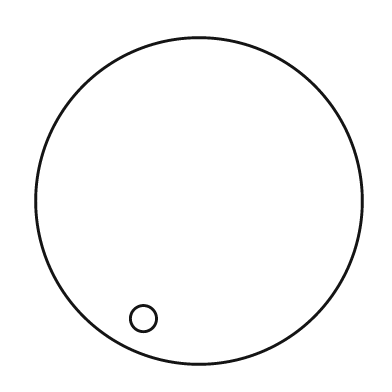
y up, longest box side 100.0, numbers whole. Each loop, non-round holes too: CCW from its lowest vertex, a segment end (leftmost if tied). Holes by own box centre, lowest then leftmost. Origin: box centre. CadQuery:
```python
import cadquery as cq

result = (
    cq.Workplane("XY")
    .moveTo(0.0, 0.0)
    .circle(50.0)
    .moveTo(-17.0, -36.0)
    .circle(4.0)
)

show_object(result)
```